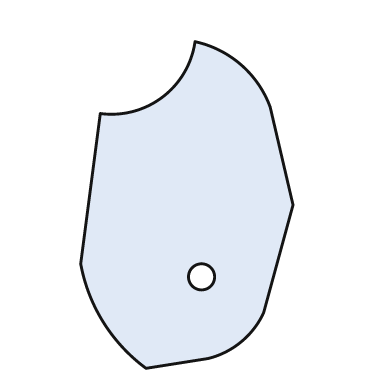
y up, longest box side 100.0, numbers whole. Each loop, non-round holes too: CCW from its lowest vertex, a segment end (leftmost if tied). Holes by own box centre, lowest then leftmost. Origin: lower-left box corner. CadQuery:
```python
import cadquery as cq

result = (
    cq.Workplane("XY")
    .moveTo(20.0, 0.0)
    .lineTo(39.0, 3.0)
    .threePointArc((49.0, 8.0), (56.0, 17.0))
    .lineTo(65.0, 50.0)
    .lineTo(58.0, 80.0)
    .threePointArc((49.0, 93.0), (35.0, 100.0))
    .threePointArc((25.0, 83.0), (6.0, 78.0))
    .lineTo(0.0, 32.0)
    .threePointArc((7.0, 14.0), (20.0, 0.0))
    .close()
    .moveTo(37.0, 28.0)
    .circle(4.0)
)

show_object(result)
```